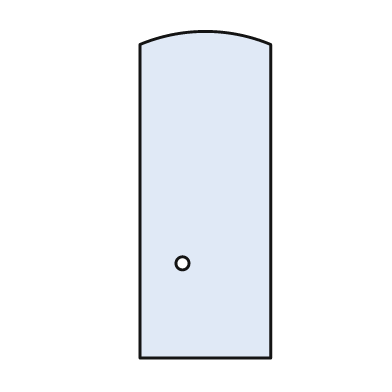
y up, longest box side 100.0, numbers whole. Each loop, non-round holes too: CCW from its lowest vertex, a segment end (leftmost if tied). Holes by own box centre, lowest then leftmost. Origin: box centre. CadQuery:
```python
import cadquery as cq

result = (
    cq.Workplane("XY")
    .moveTo(-20.0, -50.0)
    .lineTo(20.0, -50.0)
    .lineTo(20.0, 46.0)
    .threePointArc((0.0, 50.0), (-20.0, 46.0))
    .close()
    .moveTo(-7.0, -21.0)
    .circle(2.0)
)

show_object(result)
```